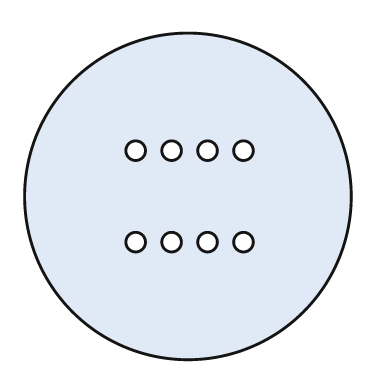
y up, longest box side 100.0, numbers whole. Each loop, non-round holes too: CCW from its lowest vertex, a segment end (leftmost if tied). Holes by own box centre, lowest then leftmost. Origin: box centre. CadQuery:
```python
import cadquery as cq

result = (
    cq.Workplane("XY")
    .moveTo(0.0, 0.0)
    .circle(50.0)
    .moveTo(-16.0, -14.0)
    .circle(3.0)
    .moveTo(-5.0, -14.0)
    .circle(3.0)
    .moveTo(6.0, -14.0)
    .circle(3.0)
    .moveTo(17.0, -14.0)
    .circle(3.0)
    .moveTo(-16.0, 14.0)
    .circle(3.0)
    .moveTo(-5.0, 14.0)
    .circle(3.0)
    .moveTo(6.0, 14.0)
    .circle(3.0)
    .moveTo(17.0, 14.0)
    .circle(3.0)
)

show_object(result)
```